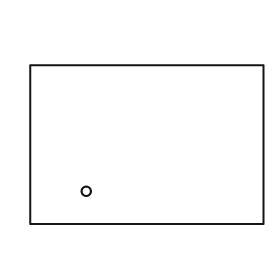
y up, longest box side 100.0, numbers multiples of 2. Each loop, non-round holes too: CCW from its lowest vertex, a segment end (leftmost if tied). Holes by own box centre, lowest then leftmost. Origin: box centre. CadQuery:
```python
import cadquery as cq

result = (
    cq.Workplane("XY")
    .moveTo(-50.0, -34.0)
    .lineTo(50.0, -34.0)
    .lineTo(50.0, 34.0)
    .lineTo(-50.0, 34.0)
    .close()
    .moveTo(-26.0, -20.0)
    .circle(2.0)
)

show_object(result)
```